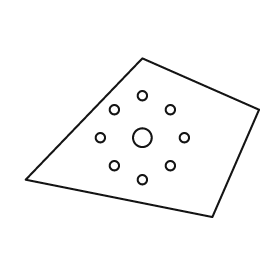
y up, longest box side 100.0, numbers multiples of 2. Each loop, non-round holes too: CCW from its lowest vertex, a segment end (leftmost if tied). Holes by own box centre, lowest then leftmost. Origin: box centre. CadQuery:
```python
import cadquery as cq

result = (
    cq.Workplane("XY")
    .moveTo(30.0, -34.0)
    .lineTo(50.0, 12.0)
    .lineTo(0.0, 34.0)
    .lineTo(-50.0, -18.0)
    .close()
    .moveTo(0.0, -18.0)
    .circle(2.0)
    .moveTo(-12.0, -12.0)
    .circle(2.0)
    .moveTo(12.0, -12.0)
    .circle(2.0)
    .moveTo(-18.0, 0.0)
    .circle(2.0)
    .moveTo(0.0, 0.0)
    .circle(4.0)
    .moveTo(18.0, 0.0)
    .circle(2.0)
    .moveTo(-12.0, 12.0)
    .circle(2.0)
    .moveTo(12.0, 12.0)
    .circle(2.0)
    .moveTo(0.0, 18.0)
    .circle(2.0)
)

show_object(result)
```